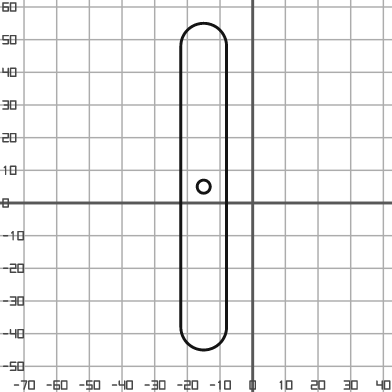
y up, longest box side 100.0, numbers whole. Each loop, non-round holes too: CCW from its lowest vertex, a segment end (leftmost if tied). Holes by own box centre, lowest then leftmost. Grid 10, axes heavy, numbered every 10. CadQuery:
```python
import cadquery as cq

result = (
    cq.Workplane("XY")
    .moveTo(-22.0, -38.0)
    .threePointArc((-15.0, -45.0), (-8.0, -38.0))
    .lineTo(-8.0, 48.0)
    .threePointArc((-15.0, 55.0), (-22.0, 48.0))
    .close()
    .moveTo(-15.0, 5.0)
    .circle(2.0)
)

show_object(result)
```